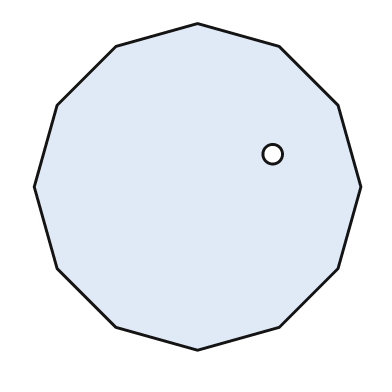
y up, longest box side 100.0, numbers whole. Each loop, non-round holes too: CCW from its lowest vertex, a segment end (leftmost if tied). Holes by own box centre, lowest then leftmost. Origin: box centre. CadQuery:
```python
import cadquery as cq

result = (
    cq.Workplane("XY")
    .moveTo(0.0, -50.0)
    .lineTo(25.0, -43.0)
    .lineTo(43.0, -25.0)
    .lineTo(50.0, 0.0)
    .lineTo(43.0, 25.0)
    .lineTo(25.0, 43.0)
    .lineTo(0.0, 50.0)
    .lineTo(-25.0, 43.0)
    .lineTo(-43.0, 25.0)
    .lineTo(-50.0, 0.0)
    .lineTo(-43.0, -25.0)
    .lineTo(-25.0, -43.0)
    .close()
    .moveTo(23.0, 10.0)
    .circle(3.0)
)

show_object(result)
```